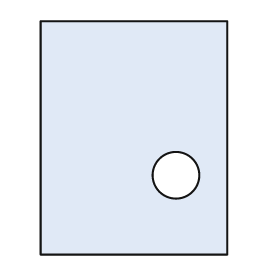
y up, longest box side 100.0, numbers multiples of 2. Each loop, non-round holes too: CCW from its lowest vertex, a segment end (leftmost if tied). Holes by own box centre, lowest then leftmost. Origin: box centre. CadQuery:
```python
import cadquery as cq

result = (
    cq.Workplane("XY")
    .moveTo(-40.0, -50.0)
    .lineTo(40.0, -50.0)
    .lineTo(40.0, 50.0)
    .lineTo(-40.0, 50.0)
    .close()
    .moveTo(18.0, -16.0)
    .circle(10.0)
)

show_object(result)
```